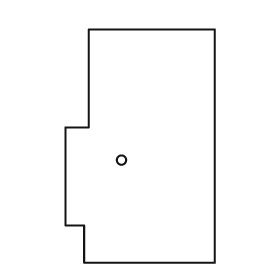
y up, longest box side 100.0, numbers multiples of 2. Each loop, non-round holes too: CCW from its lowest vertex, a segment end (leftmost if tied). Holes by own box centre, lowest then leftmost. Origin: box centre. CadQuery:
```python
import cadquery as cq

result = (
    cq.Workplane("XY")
    .moveTo(-24.0, -50.0)
    .lineTo(32.0, -50.0)
    .lineTo(32.0, 50.0)
    .lineTo(-22.0, 50.0)
    .lineTo(-22.0, 8.0)
    .lineTo(-32.0, 8.0)
    .lineTo(-32.0, -34.0)
    .lineTo(-24.0, -34.0)
    .close()
    .moveTo(-8.0, -6.0)
    .circle(2.0)
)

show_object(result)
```